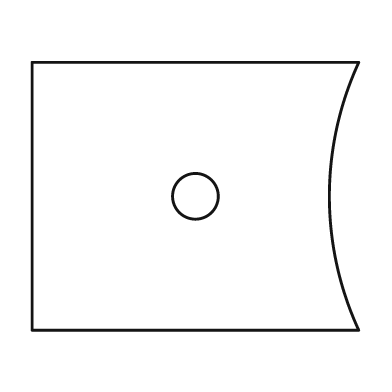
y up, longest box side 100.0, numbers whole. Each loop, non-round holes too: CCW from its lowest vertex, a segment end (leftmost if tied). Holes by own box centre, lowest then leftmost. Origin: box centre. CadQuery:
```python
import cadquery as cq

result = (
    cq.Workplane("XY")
    .moveTo(-50.0, -41.0)
    .lineTo(50.0, -41.0)
    .threePointArc((41.0, 0.0), (50.0, 41.0))
    .lineTo(-50.0, 41.0)
    .close()
    .moveTo(0.0, 0.0)
    .circle(7.0)
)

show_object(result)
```